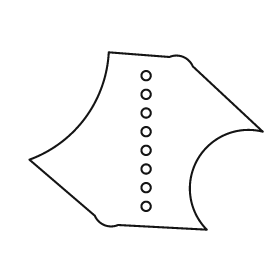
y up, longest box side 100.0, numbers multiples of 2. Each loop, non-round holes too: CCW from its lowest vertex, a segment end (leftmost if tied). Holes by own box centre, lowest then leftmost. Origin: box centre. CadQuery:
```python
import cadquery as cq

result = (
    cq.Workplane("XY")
    .moveTo(26.0, -38.0)
    .threePointArc((22.0, -8.0), (50.0, 4.0))
    .lineTo(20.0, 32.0)
    .threePointArc((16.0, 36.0), (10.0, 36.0))
    .lineTo(-16.0, 38.0)
    .threePointArc((-26.0, 10.0), (-50.0, -8.0))
    .lineTo(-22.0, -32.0)
    .threePointArc((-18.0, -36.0), (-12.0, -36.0))
    .close()
    .moveTo(0.0, -28.0)
    .circle(2.0)
    .moveTo(0.0, -20.0)
    .circle(2.0)
    .moveTo(0.0, -12.0)
    .circle(2.0)
    .moveTo(0.0, -4.0)
    .circle(2.0)
    .moveTo(0.0, 4.0)
    .circle(2.0)
    .moveTo(0.0, 12.0)
    .circle(2.0)
    .moveTo(0.0, 20.0)
    .circle(2.0)
    .moveTo(0.0, 28.0)
    .circle(2.0)
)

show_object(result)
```